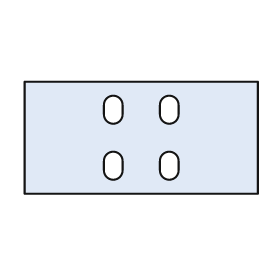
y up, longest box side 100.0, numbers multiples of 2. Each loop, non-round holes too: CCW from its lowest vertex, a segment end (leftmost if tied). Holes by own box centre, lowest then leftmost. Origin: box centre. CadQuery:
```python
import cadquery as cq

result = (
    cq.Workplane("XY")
    .moveTo(-50.0, -24.0)
    .lineTo(50.0, -24.0)
    .lineTo(50.0, 24.0)
    .lineTo(-50.0, 24.0)
    .close()
    .moveTo(-16.0, -14.0)
    .threePointArc((-12.0, -18.0), (-8.0, -14.0))
    .lineTo(-8.0, -10.0)
    .threePointArc((-12.0, -6.0), (-16.0, -10.0))
    .close()
    .moveTo(8.0, -14.0)
    .threePointArc((12.0, -18.0), (16.0, -14.0))
    .lineTo(16.0, -10.0)
    .threePointArc((12.0, -6.0), (8.0, -10.0))
    .close()
    .moveTo(-16.0, 10.0)
    .threePointArc((-12.0, 6.0), (-8.0, 10.0))
    .lineTo(-8.0, 14.0)
    .threePointArc((-12.0, 18.0), (-16.0, 14.0))
    .close()
    .moveTo(8.0, 10.0)
    .threePointArc((12.0, 6.0), (16.0, 10.0))
    .lineTo(16.0, 14.0)
    .threePointArc((12.0, 18.0), (8.0, 14.0))
    .close()
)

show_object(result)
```